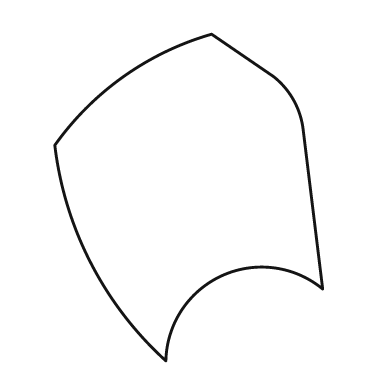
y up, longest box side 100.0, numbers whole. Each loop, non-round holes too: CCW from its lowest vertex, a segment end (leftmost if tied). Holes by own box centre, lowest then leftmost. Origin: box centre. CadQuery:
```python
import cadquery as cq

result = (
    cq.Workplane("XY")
    .moveTo(-7.0, -50.0)
    .threePointArc((10.0, -24.0), (41.0, -28.0))
    .lineTo(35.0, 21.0)
    .threePointArc((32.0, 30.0), (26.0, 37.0))
    .lineTo(7.0, 50.0)
    .threePointArc((-20.0, 37.0), (-41.0, 16.0))
    .threePointArc((-30.0, -20.0), (-7.0, -50.0))
    .close()
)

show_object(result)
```